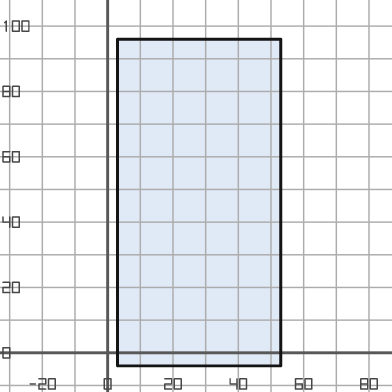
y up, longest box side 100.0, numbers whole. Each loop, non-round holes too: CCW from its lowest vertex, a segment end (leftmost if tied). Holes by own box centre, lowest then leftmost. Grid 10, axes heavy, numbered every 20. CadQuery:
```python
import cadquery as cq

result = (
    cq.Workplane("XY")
    .moveTo(3.0, -4.0)
    .lineTo(53.0, -4.0)
    .lineTo(53.0, 96.0)
    .lineTo(3.0, 96.0)
    .close()
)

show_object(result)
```